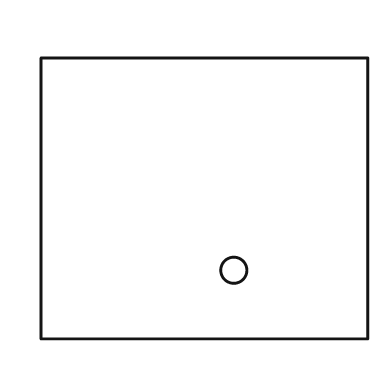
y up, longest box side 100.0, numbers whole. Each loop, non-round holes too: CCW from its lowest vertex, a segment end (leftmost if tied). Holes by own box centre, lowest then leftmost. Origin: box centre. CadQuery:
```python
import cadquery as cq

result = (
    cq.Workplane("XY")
    .moveTo(-50.0, -43.0)
    .lineTo(50.0, -43.0)
    .lineTo(50.0, 43.0)
    .lineTo(-50.0, 43.0)
    .close()
    .moveTo(9.0, -22.0)
    .circle(4.0)
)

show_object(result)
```